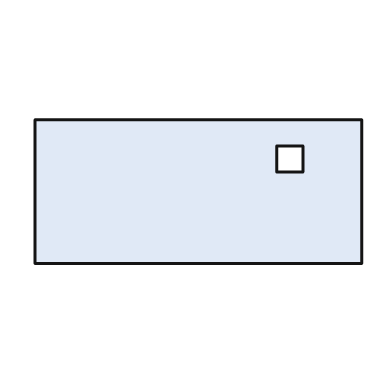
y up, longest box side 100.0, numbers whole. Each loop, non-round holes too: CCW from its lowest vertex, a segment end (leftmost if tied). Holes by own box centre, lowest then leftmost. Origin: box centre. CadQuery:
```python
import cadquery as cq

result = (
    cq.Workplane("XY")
    .moveTo(-50.0, -22.0)
    .lineTo(50.0, -22.0)
    .lineTo(50.0, 22.0)
    .lineTo(-50.0, 22.0)
    .close()
    .moveTo(24.0, 6.0)
    .lineTo(32.0, 6.0)
    .lineTo(32.0, 14.0)
    .lineTo(24.0, 14.0)
    .close()
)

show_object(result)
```